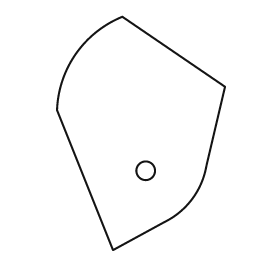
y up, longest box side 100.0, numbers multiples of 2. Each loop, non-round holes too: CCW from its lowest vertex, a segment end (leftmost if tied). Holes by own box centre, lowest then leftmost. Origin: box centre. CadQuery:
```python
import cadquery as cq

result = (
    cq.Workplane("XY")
    .moveTo(-12.0, -50.0)
    .lineTo(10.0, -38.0)
    .threePointArc((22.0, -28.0), (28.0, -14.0))
    .lineTo(36.0, 20.0)
    .lineTo(-8.0, 50.0)
    .threePointArc((-28.0, 34.0), (-36.0, 10.0))
    .close()
    .moveTo(2.0, -16.0)
    .circle(4.0)
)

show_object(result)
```